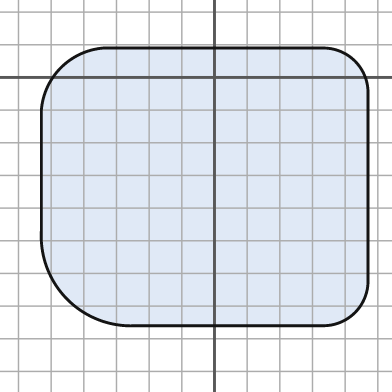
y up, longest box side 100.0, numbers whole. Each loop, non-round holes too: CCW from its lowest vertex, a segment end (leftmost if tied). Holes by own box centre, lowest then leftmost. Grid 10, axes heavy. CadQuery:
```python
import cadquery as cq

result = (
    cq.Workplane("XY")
    .moveTo(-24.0, -76.0)
    .lineTo(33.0, -76.0)
    .threePointArc((43.0, -72.0), (47.0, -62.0))
    .lineTo(47.0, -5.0)
    .threePointArc((43.0, 5.0), (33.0, 9.0))
    .lineTo(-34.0, 9.0)
    .threePointArc((-47.0, 3.0), (-53.0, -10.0))
    .lineTo(-53.0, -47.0)
    .threePointArc((-45.0, -68.0), (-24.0, -76.0))
    .close()
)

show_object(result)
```